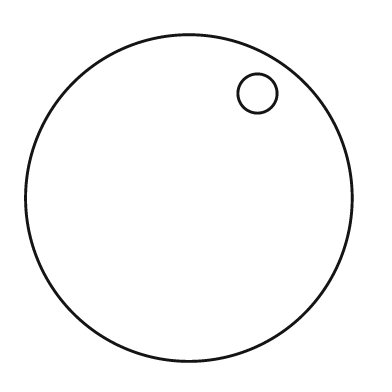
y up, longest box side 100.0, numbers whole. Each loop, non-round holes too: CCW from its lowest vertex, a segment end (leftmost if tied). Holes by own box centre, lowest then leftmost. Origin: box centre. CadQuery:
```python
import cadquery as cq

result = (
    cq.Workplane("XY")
    .moveTo(0.0, 0.0)
    .circle(50.0)
    .moveTo(21.0, 32.0)
    .circle(6.0)
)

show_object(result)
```